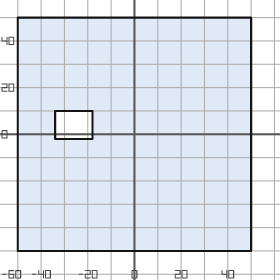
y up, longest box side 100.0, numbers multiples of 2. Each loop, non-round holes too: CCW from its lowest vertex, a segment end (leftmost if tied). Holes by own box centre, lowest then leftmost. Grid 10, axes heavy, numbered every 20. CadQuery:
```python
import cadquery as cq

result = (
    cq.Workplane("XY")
    .moveTo(-50.0, -50.0)
    .lineTo(50.0, -50.0)
    .lineTo(50.0, 50.0)
    .lineTo(-50.0, 50.0)
    .close()
    .moveTo(-34.0, -2.0)
    .lineTo(-18.0, -2.0)
    .lineTo(-18.0, 10.0)
    .lineTo(-34.0, 10.0)
    .close()
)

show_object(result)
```